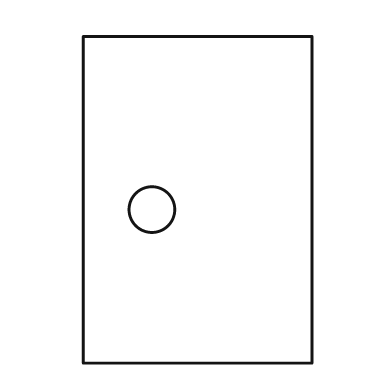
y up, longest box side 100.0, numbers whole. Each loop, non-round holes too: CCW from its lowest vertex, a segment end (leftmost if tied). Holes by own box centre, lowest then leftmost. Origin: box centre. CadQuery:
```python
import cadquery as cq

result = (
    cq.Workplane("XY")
    .moveTo(-35.0, -50.0)
    .lineTo(35.0, -50.0)
    .lineTo(35.0, 50.0)
    .lineTo(-35.0, 50.0)
    .close()
    .moveTo(-14.0, -3.0)
    .circle(7.0)
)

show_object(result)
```